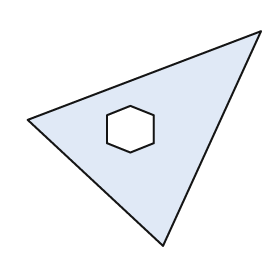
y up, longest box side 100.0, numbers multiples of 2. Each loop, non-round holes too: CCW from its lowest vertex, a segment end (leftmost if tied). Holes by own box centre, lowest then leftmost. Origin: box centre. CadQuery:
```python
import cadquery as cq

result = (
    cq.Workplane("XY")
    .moveTo(8.0, -46.0)
    .lineTo(50.0, 46.0)
    .lineTo(-50.0, 8.0)
    .close()
    .moveTo(-6.0, -6.0)
    .lineTo(4.0, -2.0)
    .lineTo(4.0, 10.0)
    .lineTo(-6.0, 14.0)
    .lineTo(-16.0, 10.0)
    .lineTo(-16.0, -2.0)
    .close()
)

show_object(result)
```